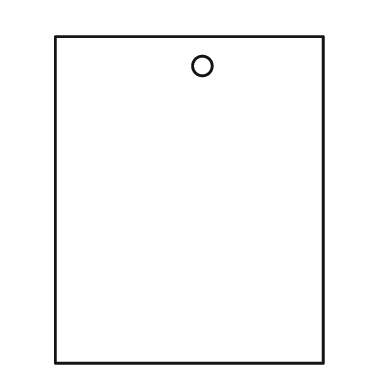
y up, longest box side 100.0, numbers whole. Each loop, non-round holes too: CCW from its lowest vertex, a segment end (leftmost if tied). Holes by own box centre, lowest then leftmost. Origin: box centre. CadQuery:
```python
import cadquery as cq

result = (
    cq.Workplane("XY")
    .moveTo(-41.0, -50.0)
    .lineTo(41.0, -50.0)
    .lineTo(41.0, 50.0)
    .lineTo(-41.0, 50.0)
    .close()
    .moveTo(4.0, 41.0)
    .circle(3.0)
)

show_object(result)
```